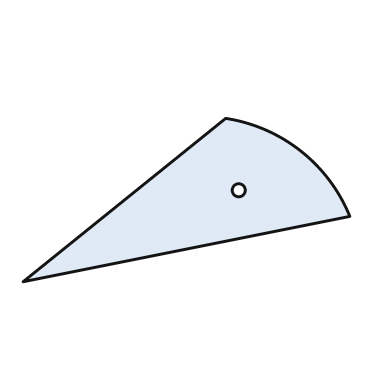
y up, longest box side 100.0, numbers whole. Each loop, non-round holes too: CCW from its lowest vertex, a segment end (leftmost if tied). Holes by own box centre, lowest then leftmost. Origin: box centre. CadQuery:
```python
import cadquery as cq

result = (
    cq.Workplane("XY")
    .moveTo(-50.0, -25.0)
    .lineTo(50.0, -5.0)
    .threePointArc((35.0, 15.0), (12.0, 25.0))
    .close()
    .moveTo(16.0, 3.0)
    .circle(2.0)
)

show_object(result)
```